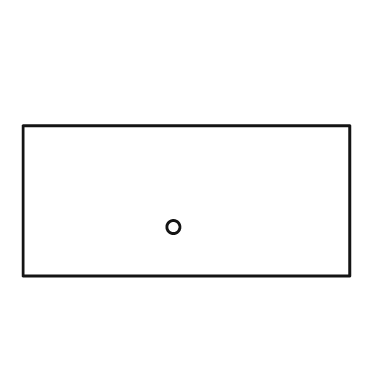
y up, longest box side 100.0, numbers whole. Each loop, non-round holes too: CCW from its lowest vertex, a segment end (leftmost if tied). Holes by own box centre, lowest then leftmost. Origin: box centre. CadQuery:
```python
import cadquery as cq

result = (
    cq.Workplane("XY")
    .moveTo(-50.0, -23.0)
    .lineTo(50.0, -23.0)
    .lineTo(50.0, 23.0)
    .lineTo(-50.0, 23.0)
    .close()
    .moveTo(-4.0, -8.0)
    .circle(2.0)
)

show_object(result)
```